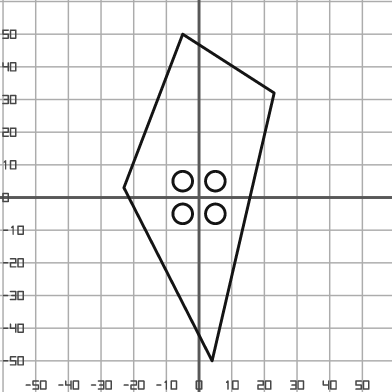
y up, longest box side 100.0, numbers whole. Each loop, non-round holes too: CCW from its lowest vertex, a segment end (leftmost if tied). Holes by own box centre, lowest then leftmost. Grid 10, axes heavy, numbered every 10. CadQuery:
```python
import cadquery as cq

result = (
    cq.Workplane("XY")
    .moveTo(4.0, -50.0)
    .lineTo(23.0, 32.0)
    .lineTo(-5.0, 50.0)
    .lineTo(-23.0, 3.0)
    .close()
    .moveTo(-5.0, -5.0)
    .circle(3.0)
    .moveTo(5.0, -5.0)
    .circle(3.0)
    .moveTo(-5.0, 5.0)
    .circle(3.0)
    .moveTo(5.0, 5.0)
    .circle(3.0)
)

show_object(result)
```